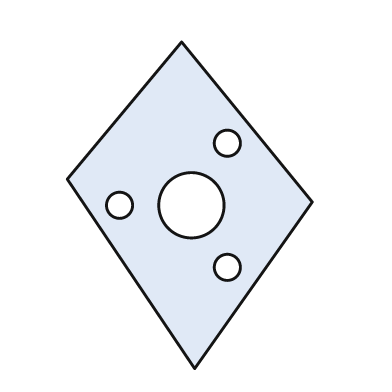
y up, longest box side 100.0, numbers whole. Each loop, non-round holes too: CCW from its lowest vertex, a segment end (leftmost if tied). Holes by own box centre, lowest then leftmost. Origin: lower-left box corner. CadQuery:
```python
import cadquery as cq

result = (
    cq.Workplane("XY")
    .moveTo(39.0, 0.0)
    .lineTo(75.0, 51.0)
    .lineTo(35.0, 100.0)
    .lineTo(0.0, 58.0)
    .close()
    .moveTo(49.0, 31.0)
    .circle(4.0)
    .moveTo(16.0, 50.0)
    .circle(4.0)
    .moveTo(38.0, 50.0)
    .circle(10.0)
    .moveTo(49.0, 69.0)
    .circle(4.0)
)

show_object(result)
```